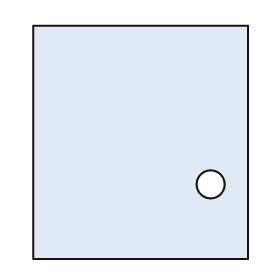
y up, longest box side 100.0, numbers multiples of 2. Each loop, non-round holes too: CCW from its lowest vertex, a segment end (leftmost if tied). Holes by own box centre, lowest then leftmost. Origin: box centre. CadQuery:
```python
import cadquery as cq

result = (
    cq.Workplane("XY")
    .moveTo(-46.0, -50.0)
    .lineTo(46.0, -50.0)
    .lineTo(46.0, 50.0)
    .lineTo(-46.0, 50.0)
    .close()
    .moveTo(30.0, -18.0)
    .circle(6.0)
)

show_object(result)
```